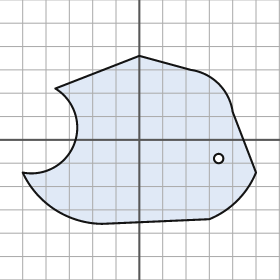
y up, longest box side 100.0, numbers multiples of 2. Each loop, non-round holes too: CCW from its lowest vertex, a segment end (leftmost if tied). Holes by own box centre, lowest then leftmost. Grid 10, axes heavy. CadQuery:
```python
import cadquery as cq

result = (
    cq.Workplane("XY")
    .moveTo(-16.0, -36.0)
    .lineTo(30.0, -34.0)
    .threePointArc((42.0, -26.0), (50.0, -14.0))
    .lineTo(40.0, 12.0)
    .threePointArc((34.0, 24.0), (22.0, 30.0))
    .lineTo(0.0, 36.0)
    .lineTo(-36.0, 22.0)
    .threePointArc((-28.0, -2.0), (-50.0, -14.0))
    .threePointArc((-36.0, -30.0), (-16.0, -36.0))
    .close()
    .moveTo(34.0, -8.0)
    .circle(2.0)
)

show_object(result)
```